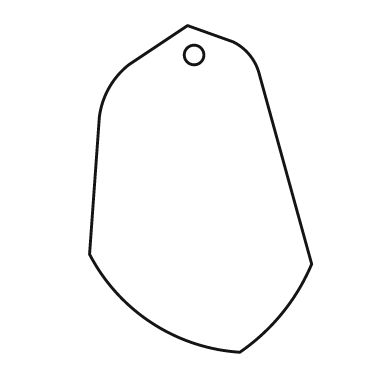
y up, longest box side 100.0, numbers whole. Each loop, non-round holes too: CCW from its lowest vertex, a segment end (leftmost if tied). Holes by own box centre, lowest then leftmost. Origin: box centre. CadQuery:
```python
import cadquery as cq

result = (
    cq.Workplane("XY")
    .moveTo(12.0, -50.0)
    .threePointArc((25.0, -38.0), (34.0, -23.0))
    .lineTo(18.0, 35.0)
    .threePointArc((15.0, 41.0), (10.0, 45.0))
    .lineTo(-4.0, 50.0)
    .lineTo(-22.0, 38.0)
    .threePointArc((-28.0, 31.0), (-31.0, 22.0))
    .lineTo(-34.0, -20.0)
    .threePointArc((-15.0, -41.0), (12.0, -50.0))
    .close()
    .moveTo(-2.0, 41.0)
    .circle(3.0)
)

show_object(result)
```